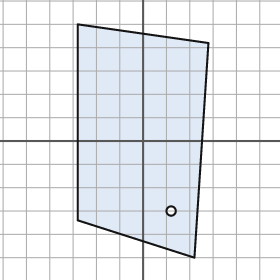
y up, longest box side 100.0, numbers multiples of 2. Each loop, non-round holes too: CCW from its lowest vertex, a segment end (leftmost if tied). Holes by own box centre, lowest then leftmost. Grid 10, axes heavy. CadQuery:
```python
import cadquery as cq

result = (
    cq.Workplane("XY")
    .moveTo(22.0, -50.0)
    .lineTo(28.0, 42.0)
    .lineTo(-28.0, 50.0)
    .lineTo(-28.0, -34.0)
    .close()
    .moveTo(12.0, -30.0)
    .circle(2.0)
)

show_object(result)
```